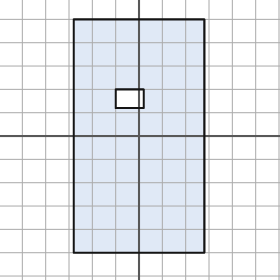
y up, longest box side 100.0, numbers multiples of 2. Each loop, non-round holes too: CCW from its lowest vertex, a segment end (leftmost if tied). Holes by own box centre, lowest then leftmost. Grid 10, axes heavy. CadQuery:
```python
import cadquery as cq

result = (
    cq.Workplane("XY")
    .moveTo(-28.0, -50.0)
    .lineTo(28.0, -50.0)
    .lineTo(28.0, 50.0)
    .lineTo(-28.0, 50.0)
    .close()
    .moveTo(-10.0, 12.0)
    .lineTo(2.0, 12.0)
    .lineTo(2.0, 20.0)
    .lineTo(-10.0, 20.0)
    .close()
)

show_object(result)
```